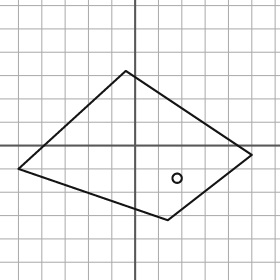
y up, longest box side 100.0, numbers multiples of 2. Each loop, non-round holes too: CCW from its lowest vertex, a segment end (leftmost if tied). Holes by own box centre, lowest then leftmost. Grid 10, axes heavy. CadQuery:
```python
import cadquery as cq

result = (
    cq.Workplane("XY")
    .moveTo(14.0, -32.0)
    .lineTo(50.0, -4.0)
    .lineTo(-4.0, 32.0)
    .lineTo(-50.0, -10.0)
    .close()
    .moveTo(18.0, -14.0)
    .circle(2.0)
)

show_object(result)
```